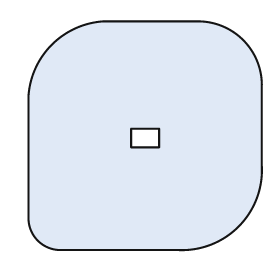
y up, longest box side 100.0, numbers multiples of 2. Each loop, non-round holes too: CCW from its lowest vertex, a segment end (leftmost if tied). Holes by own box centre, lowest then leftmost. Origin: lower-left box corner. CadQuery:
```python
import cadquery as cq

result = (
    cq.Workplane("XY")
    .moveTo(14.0, 0.0)
    .lineTo(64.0, 0.0)
    .threePointArc((90.0, 10.0), (100.0, 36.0))
    .lineTo(100.0, 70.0)
    .threePointArc((92.0, 90.0), (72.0, 98.0))
    .lineTo(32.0, 98.0)
    .threePointArc((10.0, 88.0), (0.0, 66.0))
    .lineTo(0.0, 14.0)
    .threePointArc((4.0, 4.0), (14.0, 0.0))
    .close()
    .moveTo(44.0, 44.0)
    .lineTo(56.0, 44.0)
    .lineTo(56.0, 52.0)
    .lineTo(44.0, 52.0)
    .close()
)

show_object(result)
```